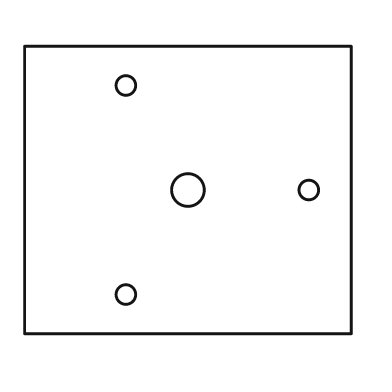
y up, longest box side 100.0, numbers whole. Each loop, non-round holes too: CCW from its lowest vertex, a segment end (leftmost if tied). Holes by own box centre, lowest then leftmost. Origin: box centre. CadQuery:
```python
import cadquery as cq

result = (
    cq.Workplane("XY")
    .moveTo(-50.0, -44.0)
    .lineTo(50.0, -44.0)
    .lineTo(50.0, 44.0)
    .lineTo(-50.0, 44.0)
    .close()
    .moveTo(-19.0, -32.0)
    .circle(3.0)
    .moveTo(0.0, 0.0)
    .circle(5.0)
    .moveTo(37.0, 0.0)
    .circle(3.0)
    .moveTo(-19.0, 32.0)
    .circle(3.0)
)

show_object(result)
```